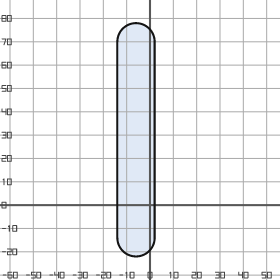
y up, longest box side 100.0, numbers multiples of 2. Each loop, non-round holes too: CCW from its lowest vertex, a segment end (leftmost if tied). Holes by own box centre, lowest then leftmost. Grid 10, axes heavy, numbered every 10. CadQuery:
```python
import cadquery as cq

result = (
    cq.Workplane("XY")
    .moveTo(-14.0, -14.0)
    .threePointArc((-6.0, -22.0), (2.0, -14.0))
    .lineTo(2.0, 70.0)
    .threePointArc((-6.0, 78.0), (-14.0, 70.0))
    .close()
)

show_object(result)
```